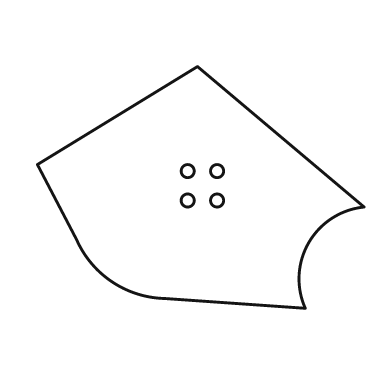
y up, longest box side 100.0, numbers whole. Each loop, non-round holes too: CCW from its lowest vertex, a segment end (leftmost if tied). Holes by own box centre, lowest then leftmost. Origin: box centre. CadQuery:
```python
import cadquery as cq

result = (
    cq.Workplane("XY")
    .moveTo(32.0, -37.0)
    .threePointArc((33.0, -17.0), (50.0, -6.0))
    .lineTo(-1.0, 37.0)
    .lineTo(-50.0, 7.0)
    .lineTo(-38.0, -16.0)
    .threePointArc((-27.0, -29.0), (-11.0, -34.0))
    .close()
    .moveTo(-4.0, -4.0)
    .circle(2.0)
    .moveTo(5.0, -4.0)
    .circle(2.0)
    .moveTo(-4.0, 5.0)
    .circle(2.0)
    .moveTo(5.0, 5.0)
    .circle(2.0)
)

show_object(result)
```